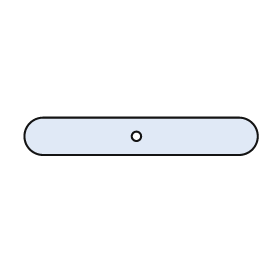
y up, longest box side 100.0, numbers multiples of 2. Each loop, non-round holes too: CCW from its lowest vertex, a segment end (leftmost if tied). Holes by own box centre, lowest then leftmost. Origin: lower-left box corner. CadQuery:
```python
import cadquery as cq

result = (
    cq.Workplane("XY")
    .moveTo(8.0, 0.0)
    .lineTo(92.0, 0.0)
    .threePointArc((100.0, 8.0), (92.0, 16.0))
    .lineTo(8.0, 16.0)
    .threePointArc((0.0, 8.0), (8.0, 0.0))
    .close()
    .moveTo(48.0, 8.0)
    .circle(2.0)
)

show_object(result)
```